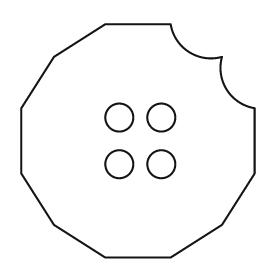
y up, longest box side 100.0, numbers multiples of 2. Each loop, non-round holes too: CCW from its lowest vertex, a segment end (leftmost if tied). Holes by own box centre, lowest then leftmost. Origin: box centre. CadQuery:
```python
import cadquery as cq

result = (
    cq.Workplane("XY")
    .moveTo(-14.0, -50.0)
    .lineTo(14.0, -50.0)
    .lineTo(36.0, -36.0)
    .lineTo(50.0, -14.0)
    .lineTo(50.0, 14.0)
    .threePointArc((38.0, 22.0), (36.0, 36.0))
    .threePointArc((22.0, 38.0), (14.0, 50.0))
    .lineTo(-14.0, 50.0)
    .lineTo(-36.0, 36.0)
    .lineTo(-50.0, 14.0)
    .lineTo(-50.0, -14.0)
    .lineTo(-36.0, -36.0)
    .close()
    .moveTo(-8.0, -10.0)
    .circle(6.0)
    .moveTo(10.0, -10.0)
    .circle(6.0)
    .moveTo(-8.0, 10.0)
    .circle(6.0)
    .moveTo(10.0, 10.0)
    .circle(6.0)
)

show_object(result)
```